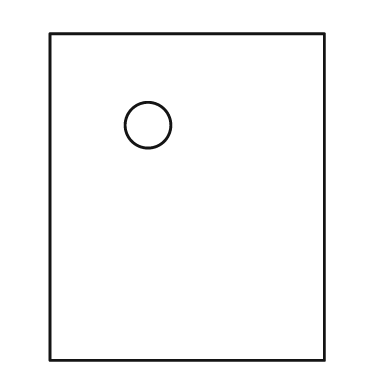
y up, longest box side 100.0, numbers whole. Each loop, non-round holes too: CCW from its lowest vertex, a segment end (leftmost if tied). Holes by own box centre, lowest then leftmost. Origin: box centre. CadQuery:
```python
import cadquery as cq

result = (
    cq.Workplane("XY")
    .moveTo(-42.0, -50.0)
    .lineTo(42.0, -50.0)
    .lineTo(42.0, 50.0)
    .lineTo(-42.0, 50.0)
    .close()
    .moveTo(-12.0, 22.0)
    .circle(7.0)
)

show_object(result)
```